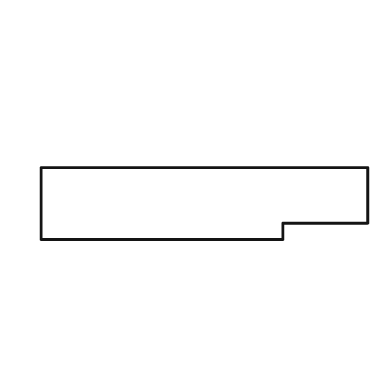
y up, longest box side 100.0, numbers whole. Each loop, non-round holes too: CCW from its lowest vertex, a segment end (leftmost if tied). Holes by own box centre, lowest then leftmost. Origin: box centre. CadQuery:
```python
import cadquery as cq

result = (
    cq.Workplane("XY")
    .moveTo(-50.0, -11.0)
    .lineTo(24.0, -11.0)
    .lineTo(24.0, -6.0)
    .lineTo(50.0, -6.0)
    .lineTo(50.0, 11.0)
    .lineTo(-50.0, 11.0)
    .close()
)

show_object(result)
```